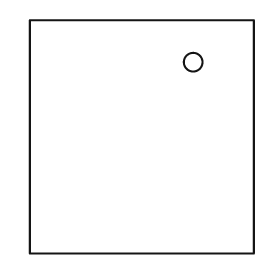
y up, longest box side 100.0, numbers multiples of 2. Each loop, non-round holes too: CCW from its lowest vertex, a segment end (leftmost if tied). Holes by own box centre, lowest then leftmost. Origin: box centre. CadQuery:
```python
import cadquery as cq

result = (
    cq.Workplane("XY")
    .moveTo(-48.0, -50.0)
    .lineTo(48.0, -50.0)
    .lineTo(48.0, 50.0)
    .lineTo(-48.0, 50.0)
    .close()
    .moveTo(22.0, 32.0)
    .circle(4.0)
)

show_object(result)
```